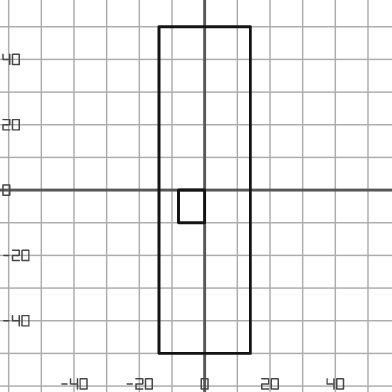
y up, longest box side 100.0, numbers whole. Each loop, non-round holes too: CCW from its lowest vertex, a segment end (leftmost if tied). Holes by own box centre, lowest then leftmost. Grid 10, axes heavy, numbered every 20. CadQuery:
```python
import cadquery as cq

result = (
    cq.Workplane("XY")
    .moveTo(-14.0, -50.0)
    .lineTo(14.0, -50.0)
    .lineTo(14.0, 50.0)
    .lineTo(-14.0, 50.0)
    .close()
    .moveTo(-8.0, -10.0)
    .lineTo(0.0, -10.0)
    .lineTo(0.0, 0.0)
    .lineTo(-8.0, 0.0)
    .close()
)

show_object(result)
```